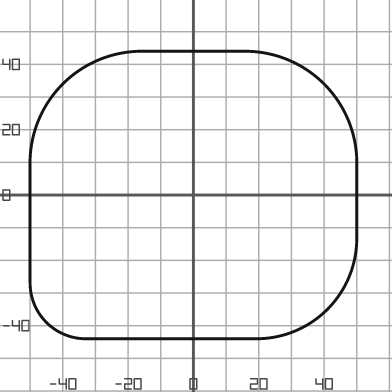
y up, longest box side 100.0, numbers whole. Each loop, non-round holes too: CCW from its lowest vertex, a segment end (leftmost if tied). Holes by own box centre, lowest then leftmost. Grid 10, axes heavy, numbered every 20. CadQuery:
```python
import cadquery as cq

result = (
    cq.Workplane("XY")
    .moveTo(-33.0, -44.0)
    .lineTo(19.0, -44.0)
    .threePointArc((41.0, -35.0), (50.0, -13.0))
    .lineTo(50.0, 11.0)
    .threePointArc((40.0, 34.0), (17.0, 44.0))
    .lineTo(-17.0, 44.0)
    .threePointArc((-40.0, 34.0), (-50.0, 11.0))
    .lineTo(-50.0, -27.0)
    .threePointArc((-45.0, -39.0), (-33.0, -44.0))
    .close()
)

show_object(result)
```